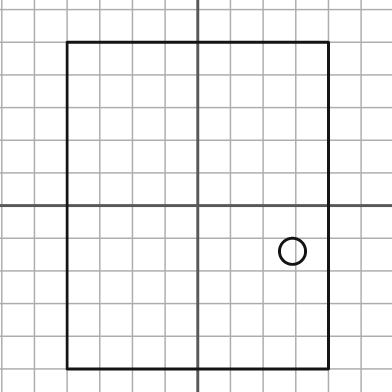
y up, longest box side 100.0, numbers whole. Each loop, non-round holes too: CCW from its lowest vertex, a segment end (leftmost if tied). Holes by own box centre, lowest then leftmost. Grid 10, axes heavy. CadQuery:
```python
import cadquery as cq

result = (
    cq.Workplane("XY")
    .moveTo(-40.0, -50.0)
    .lineTo(40.0, -50.0)
    .lineTo(40.0, 50.0)
    .lineTo(-40.0, 50.0)
    .close()
    .moveTo(29.0, -14.0)
    .circle(4.0)
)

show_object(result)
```